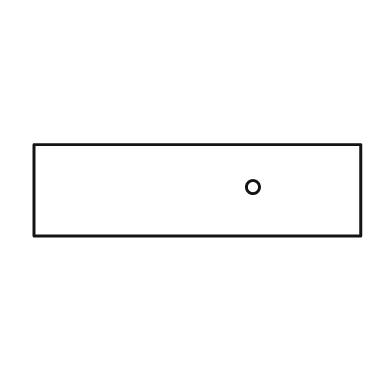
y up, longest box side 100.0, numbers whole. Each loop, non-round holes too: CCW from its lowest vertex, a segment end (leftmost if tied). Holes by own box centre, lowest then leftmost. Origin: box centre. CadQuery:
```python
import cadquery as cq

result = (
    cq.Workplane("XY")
    .moveTo(-50.0, -14.0)
    .lineTo(50.0, -14.0)
    .lineTo(50.0, 14.0)
    .lineTo(-50.0, 14.0)
    .close()
    .moveTo(17.0, 1.0)
    .circle(2.0)
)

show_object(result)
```